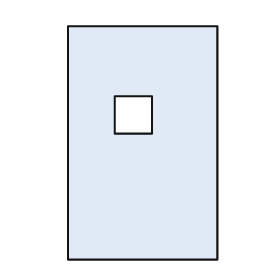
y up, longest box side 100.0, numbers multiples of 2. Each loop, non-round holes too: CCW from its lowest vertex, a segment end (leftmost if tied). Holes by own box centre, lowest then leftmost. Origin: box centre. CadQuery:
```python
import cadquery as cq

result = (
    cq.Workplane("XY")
    .moveTo(-32.0, -50.0)
    .lineTo(32.0, -50.0)
    .lineTo(32.0, 50.0)
    .lineTo(-32.0, 50.0)
    .close()
    .moveTo(-12.0, 4.0)
    .lineTo(4.0, 4.0)
    .lineTo(4.0, 20.0)
    .lineTo(-12.0, 20.0)
    .close()
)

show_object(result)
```